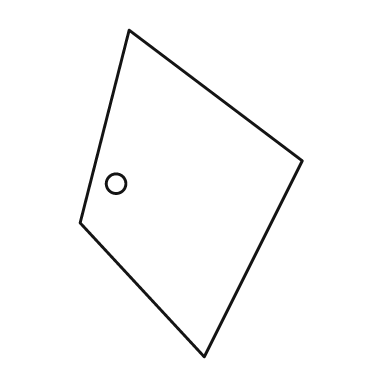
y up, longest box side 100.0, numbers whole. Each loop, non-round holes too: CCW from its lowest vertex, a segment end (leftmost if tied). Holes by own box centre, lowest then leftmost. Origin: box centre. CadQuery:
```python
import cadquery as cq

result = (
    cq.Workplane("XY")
    .moveTo(4.0, -50.0)
    .lineTo(34.0, 10.0)
    .lineTo(-19.0, 50.0)
    .lineTo(-34.0, -9.0)
    .close()
    .moveTo(-23.0, 3.0)
    .circle(3.0)
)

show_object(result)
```